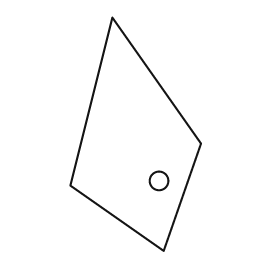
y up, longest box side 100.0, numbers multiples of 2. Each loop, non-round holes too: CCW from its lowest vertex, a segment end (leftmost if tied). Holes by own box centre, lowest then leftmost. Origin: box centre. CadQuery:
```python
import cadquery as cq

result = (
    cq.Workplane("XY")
    .moveTo(12.0, -50.0)
    .lineTo(28.0, -4.0)
    .lineTo(-10.0, 50.0)
    .lineTo(-28.0, -22.0)
    .close()
    .moveTo(10.0, -20.0)
    .circle(4.0)
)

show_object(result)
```